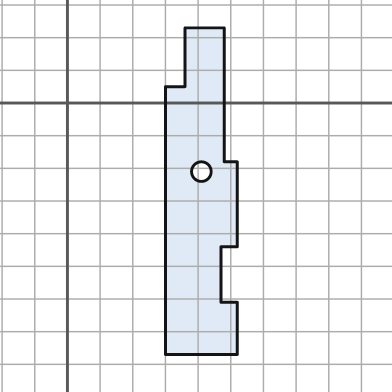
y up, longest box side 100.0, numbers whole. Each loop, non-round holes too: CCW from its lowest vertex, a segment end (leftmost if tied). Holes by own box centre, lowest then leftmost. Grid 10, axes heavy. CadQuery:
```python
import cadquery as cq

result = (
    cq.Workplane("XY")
    .moveTo(30.0, -77.0)
    .lineTo(52.0, -77.0)
    .lineTo(52.0, -61.0)
    .lineTo(47.0, -61.0)
    .lineTo(47.0, -44.0)
    .lineTo(52.0, -44.0)
    .lineTo(52.0, -18.0)
    .lineTo(48.0, -18.0)
    .lineTo(48.0, 23.0)
    .lineTo(36.0, 23.0)
    .lineTo(36.0, 5.0)
    .lineTo(30.0, 5.0)
    .close()
    .moveTo(41.0, -21.0)
    .circle(3.0)
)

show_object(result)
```